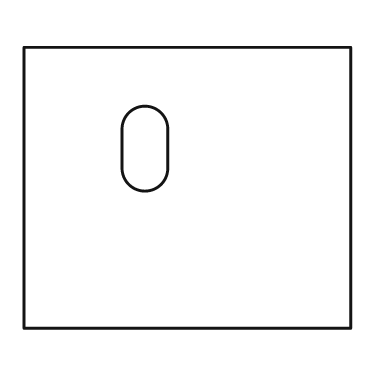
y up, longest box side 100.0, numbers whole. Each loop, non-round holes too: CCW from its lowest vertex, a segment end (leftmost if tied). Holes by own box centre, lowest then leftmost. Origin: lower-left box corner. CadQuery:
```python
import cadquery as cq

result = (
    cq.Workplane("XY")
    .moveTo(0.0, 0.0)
    .lineTo(100.0, 0.0)
    .lineTo(100.0, 86.0)
    .lineTo(0.0, 86.0)
    .close()
    .moveTo(30.0, 49.0)
    .threePointArc((37.0, 42.0), (44.0, 49.0))
    .lineTo(44.0, 61.0)
    .threePointArc((37.0, 68.0), (30.0, 61.0))
    .close()
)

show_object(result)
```